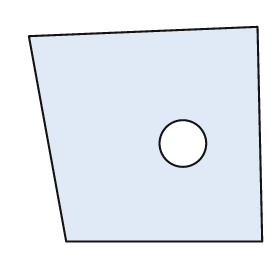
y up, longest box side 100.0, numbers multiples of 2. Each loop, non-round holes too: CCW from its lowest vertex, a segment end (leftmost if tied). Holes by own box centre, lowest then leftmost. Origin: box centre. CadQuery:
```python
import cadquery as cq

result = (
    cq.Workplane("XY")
    .moveTo(-34.0, -46.0)
    .lineTo(50.0, -46.0)
    .lineTo(48.0, 46.0)
    .lineTo(-50.0, 42.0)
    .close()
    .moveTo(16.0, -4.0)
    .circle(10.0)
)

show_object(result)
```